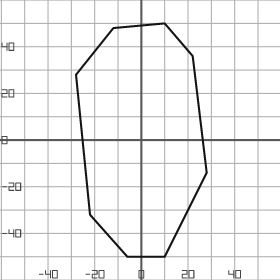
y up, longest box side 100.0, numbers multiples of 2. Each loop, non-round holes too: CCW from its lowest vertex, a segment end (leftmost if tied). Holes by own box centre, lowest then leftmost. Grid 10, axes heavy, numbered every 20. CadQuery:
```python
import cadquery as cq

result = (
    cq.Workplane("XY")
    .moveTo(-6.0, -50.0)
    .lineTo(10.0, -50.0)
    .lineTo(28.0, -14.0)
    .lineTo(22.0, 36.0)
    .lineTo(10.0, 50.0)
    .lineTo(-12.0, 48.0)
    .lineTo(-28.0, 28.0)
    .lineTo(-22.0, -32.0)
    .close()
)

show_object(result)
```